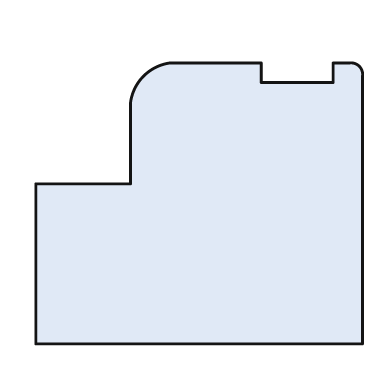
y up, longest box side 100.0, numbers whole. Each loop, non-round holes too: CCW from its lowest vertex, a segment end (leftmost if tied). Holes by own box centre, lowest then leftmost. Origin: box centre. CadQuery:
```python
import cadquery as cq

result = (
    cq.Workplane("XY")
    .moveTo(-50.0, -43.0)
    .lineTo(50.0, -43.0)
    .lineTo(50.0, 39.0)
    .threePointArc((49.0, 42.0), (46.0, 43.0))
    .lineTo(41.0, 43.0)
    .lineTo(41.0, 37.0)
    .lineTo(19.0, 37.0)
    .lineTo(19.0, 43.0)
    .lineTo(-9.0, 43.0)
    .threePointArc((-17.0, 39.0), (-21.0, 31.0))
    .lineTo(-21.0, 6.0)
    .lineTo(-50.0, 6.0)
    .close()
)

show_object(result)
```